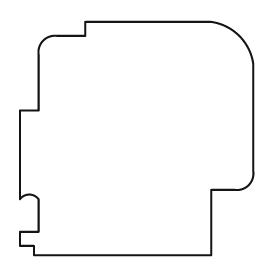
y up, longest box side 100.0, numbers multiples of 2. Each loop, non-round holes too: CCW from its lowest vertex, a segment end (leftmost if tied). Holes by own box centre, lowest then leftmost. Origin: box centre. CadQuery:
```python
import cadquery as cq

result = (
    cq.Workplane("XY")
    .moveTo(-44.0, -50.0)
    .lineTo(32.0, -50.0)
    .lineTo(32.0, -22.0)
    .lineTo(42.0, -22.0)
    .threePointArc((48.0, -20.0), (50.0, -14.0))
    .lineTo(50.0, 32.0)
    .threePointArc((44.0, 44.0), (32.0, 50.0))
    .lineTo(-22.0, 50.0)
    .lineTo(-22.0, 44.0)
    .lineTo(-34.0, 44.0)
    .threePointArc((-40.0, 42.0), (-42.0, 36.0))
    .lineTo(-42.0, 12.0)
    .lineTo(-50.0, 12.0)
    .lineTo(-50.0, -26.0)
    .threePointArc((-46.0, -24.0), (-42.0, -26.0))
    .lineTo(-42.0, -40.0)
    .lineTo(-50.0, -40.0)
    .lineTo(-50.0, -46.0)
    .lineTo(-44.0, -46.0)
    .close()
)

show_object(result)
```